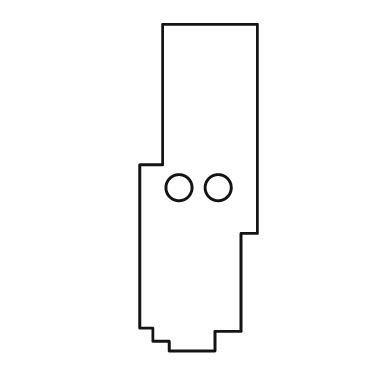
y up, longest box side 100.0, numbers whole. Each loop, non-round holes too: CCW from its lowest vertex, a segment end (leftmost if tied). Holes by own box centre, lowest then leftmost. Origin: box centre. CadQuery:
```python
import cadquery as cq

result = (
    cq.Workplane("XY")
    .moveTo(-9.0, -50.0)
    .lineTo(5.0, -50.0)
    .lineTo(5.0, -44.0)
    .lineTo(13.0, -44.0)
    .lineTo(13.0, -14.0)
    .lineTo(18.0, -14.0)
    .lineTo(18.0, 50.0)
    .lineTo(-11.0, 50.0)
    .lineTo(-11.0, 7.0)
    .lineTo(-18.0, 7.0)
    .lineTo(-18.0, -43.0)
    .lineTo(-14.0, -43.0)
    .lineTo(-14.0, -47.0)
    .lineTo(-9.0, -47.0)
    .close()
    .moveTo(-6.0, 0.0)
    .circle(4.0)
    .moveTo(6.0, 0.0)
    .circle(4.0)
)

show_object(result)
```